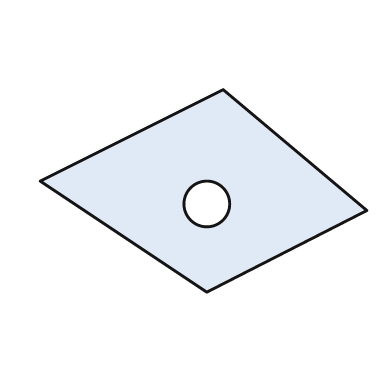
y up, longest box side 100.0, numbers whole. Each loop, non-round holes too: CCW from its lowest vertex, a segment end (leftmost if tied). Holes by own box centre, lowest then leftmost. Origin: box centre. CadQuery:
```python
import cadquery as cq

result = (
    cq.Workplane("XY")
    .moveTo(1.0, -31.0)
    .lineTo(50.0, -6.0)
    .lineTo(6.0, 31.0)
    .lineTo(-50.0, 3.0)
    .close()
    .moveTo(1.0, -4.0)
    .circle(7.0)
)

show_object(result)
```